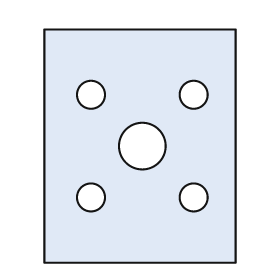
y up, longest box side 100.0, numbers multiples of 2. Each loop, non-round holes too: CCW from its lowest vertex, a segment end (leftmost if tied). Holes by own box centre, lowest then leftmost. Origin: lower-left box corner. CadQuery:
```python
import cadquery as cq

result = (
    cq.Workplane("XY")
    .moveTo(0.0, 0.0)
    .lineTo(82.0, 0.0)
    .lineTo(82.0, 100.0)
    .lineTo(0.0, 100.0)
    .close()
    .moveTo(20.0, 28.0)
    .circle(6.0)
    .moveTo(64.0, 28.0)
    .circle(6.0)
    .moveTo(42.0, 50.0)
    .circle(10.0)
    .moveTo(20.0, 72.0)
    .circle(6.0)
    .moveTo(64.0, 72.0)
    .circle(6.0)
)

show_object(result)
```